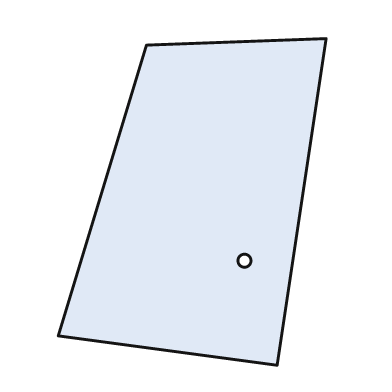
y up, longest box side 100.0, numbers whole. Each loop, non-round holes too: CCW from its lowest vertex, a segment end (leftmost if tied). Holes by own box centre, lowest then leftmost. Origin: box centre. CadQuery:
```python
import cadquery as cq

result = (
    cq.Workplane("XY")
    .moveTo(26.0, -50.0)
    .lineTo(41.0, 50.0)
    .lineTo(-14.0, 48.0)
    .lineTo(-41.0, -41.0)
    .close()
    .moveTo(16.0, -18.0)
    .circle(2.0)
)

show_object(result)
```